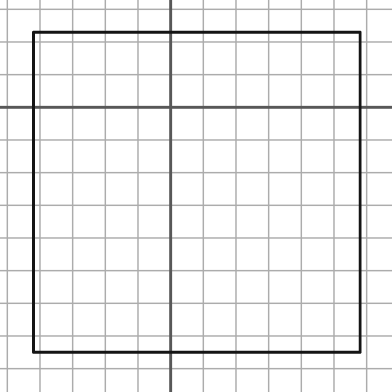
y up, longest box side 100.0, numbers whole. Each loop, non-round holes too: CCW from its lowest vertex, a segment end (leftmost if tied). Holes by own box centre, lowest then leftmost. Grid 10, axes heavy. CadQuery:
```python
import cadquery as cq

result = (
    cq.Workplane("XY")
    .moveTo(-42.0, -75.0)
    .lineTo(58.0, -75.0)
    .lineTo(58.0, 23.0)
    .lineTo(-42.0, 23.0)
    .close()
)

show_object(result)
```